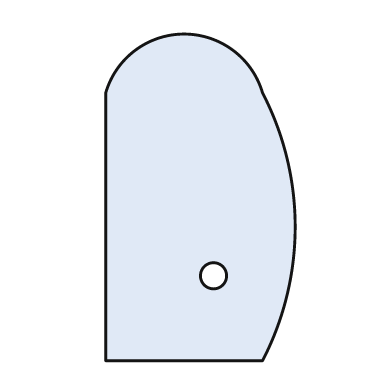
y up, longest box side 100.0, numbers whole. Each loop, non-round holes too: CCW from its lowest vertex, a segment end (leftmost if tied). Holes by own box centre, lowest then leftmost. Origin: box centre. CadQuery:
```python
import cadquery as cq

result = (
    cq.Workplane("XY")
    .moveTo(-29.0, -50.0)
    .lineTo(19.0, -50.0)
    .threePointArc((29.0, -9.0), (19.0, 32.0))
    .threePointArc((-5.0, 50.0), (-29.0, 32.0))
    .close()
    .moveTo(4.0, -24.0)
    .circle(4.0)
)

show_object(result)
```